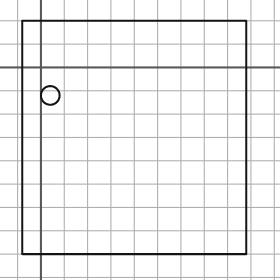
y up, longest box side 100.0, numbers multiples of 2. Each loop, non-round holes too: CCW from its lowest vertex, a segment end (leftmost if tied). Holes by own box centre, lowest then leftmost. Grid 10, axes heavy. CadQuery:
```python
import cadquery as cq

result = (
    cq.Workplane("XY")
    .moveTo(-8.0, -80.0)
    .lineTo(88.0, -80.0)
    .lineTo(88.0, 20.0)
    .lineTo(-8.0, 20.0)
    .close()
    .moveTo(4.0, -12.0)
    .circle(4.0)
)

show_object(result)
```